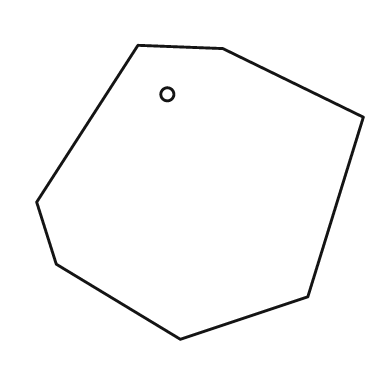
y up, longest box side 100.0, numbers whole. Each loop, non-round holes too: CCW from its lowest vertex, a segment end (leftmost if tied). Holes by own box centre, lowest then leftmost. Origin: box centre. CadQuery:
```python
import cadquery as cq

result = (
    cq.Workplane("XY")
    .moveTo(-6.0, -45.0)
    .lineTo(33.0, -32.0)
    .lineTo(50.0, 23.0)
    .lineTo(7.0, 44.0)
    .lineTo(-19.0, 45.0)
    .lineTo(-50.0, -3.0)
    .lineTo(-44.0, -22.0)
    .close()
    .moveTo(-10.0, 30.0)
    .circle(2.0)
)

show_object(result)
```